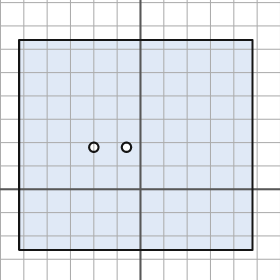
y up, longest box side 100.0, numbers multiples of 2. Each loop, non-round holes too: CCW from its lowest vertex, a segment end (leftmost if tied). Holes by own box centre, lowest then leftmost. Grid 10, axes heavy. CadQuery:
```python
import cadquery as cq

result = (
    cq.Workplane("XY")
    .moveTo(-52.0, -26.0)
    .lineTo(48.0, -26.0)
    .lineTo(48.0, 64.0)
    .lineTo(-52.0, 64.0)
    .close()
    .moveTo(-20.0, 18.0)
    .circle(2.0)
    .moveTo(-6.0, 18.0)
    .circle(2.0)
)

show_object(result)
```